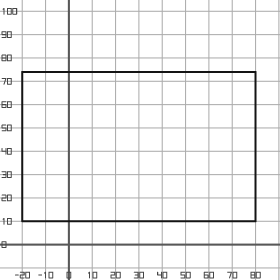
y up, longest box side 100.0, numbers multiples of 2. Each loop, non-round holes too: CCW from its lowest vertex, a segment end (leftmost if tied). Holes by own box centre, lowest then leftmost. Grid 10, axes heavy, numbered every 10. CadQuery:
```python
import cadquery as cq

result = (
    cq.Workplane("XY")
    .moveTo(-20.0, 10.0)
    .lineTo(80.0, 10.0)
    .lineTo(80.0, 74.0)
    .lineTo(-20.0, 74.0)
    .close()
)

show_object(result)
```